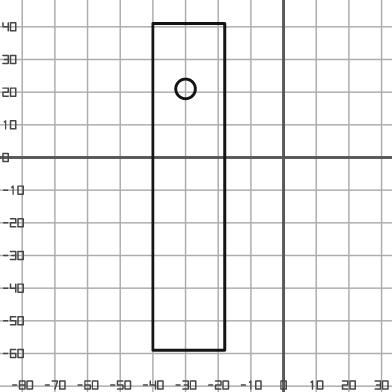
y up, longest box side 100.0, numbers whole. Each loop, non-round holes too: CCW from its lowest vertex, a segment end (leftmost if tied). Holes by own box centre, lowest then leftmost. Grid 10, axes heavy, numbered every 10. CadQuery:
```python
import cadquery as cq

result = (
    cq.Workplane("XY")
    .moveTo(-40.0, -59.0)
    .lineTo(-18.0, -59.0)
    .lineTo(-18.0, 41.0)
    .lineTo(-40.0, 41.0)
    .close()
    .moveTo(-30.0, 21.0)
    .circle(3.0)
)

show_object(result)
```